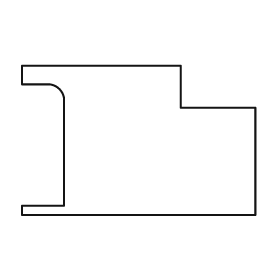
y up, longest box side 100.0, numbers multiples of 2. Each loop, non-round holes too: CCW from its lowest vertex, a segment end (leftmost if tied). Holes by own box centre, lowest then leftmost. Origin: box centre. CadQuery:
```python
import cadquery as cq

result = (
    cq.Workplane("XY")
    .moveTo(-50.0, -32.0)
    .lineTo(50.0, -32.0)
    .lineTo(50.0, 14.0)
    .lineTo(18.0, 14.0)
    .lineTo(18.0, 32.0)
    .lineTo(-50.0, 32.0)
    .lineTo(-50.0, 24.0)
    .lineTo(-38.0, 24.0)
    .threePointArc((-34.0, 22.0), (-32.0, 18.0))
    .lineTo(-32.0, -28.0)
    .lineTo(-50.0, -28.0)
    .close()
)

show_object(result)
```